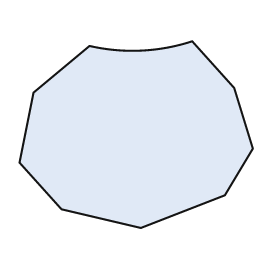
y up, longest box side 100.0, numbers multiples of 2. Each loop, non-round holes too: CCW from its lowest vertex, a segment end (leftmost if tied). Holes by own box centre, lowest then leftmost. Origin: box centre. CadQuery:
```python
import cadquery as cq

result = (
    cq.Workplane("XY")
    .moveTo(2.0, -40.0)
    .lineTo(38.0, -26.0)
    .lineTo(50.0, -6.0)
    .lineTo(42.0, 20.0)
    .lineTo(24.0, 40.0)
    .threePointArc((2.0, 36.0), (-20.0, 38.0))
    .lineTo(-44.0, 18.0)
    .lineTo(-50.0, -12.0)
    .lineTo(-32.0, -32.0)
    .close()
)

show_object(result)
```